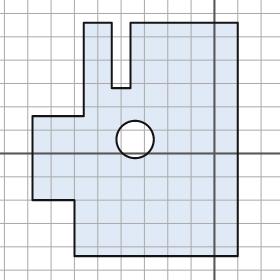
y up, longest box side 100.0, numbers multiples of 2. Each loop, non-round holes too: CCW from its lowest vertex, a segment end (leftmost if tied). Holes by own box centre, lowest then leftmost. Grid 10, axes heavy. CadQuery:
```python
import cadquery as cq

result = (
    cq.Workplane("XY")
    .moveTo(-60.0, -44.0)
    .lineTo(10.0, -44.0)
    .lineTo(10.0, 56.0)
    .lineTo(-36.0, 56.0)
    .lineTo(-36.0, 28.0)
    .lineTo(-44.0, 28.0)
    .lineTo(-44.0, 56.0)
    .lineTo(-56.0, 56.0)
    .lineTo(-56.0, 16.0)
    .lineTo(-78.0, 16.0)
    .lineTo(-78.0, -20.0)
    .lineTo(-60.0, -20.0)
    .close()
    .moveTo(-34.0, 6.0)
    .circle(8.0)
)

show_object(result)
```